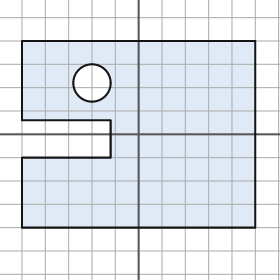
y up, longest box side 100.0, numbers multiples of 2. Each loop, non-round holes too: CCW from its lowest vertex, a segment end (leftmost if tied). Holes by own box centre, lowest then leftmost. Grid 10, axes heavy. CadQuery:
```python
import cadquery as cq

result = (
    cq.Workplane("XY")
    .moveTo(-50.0, -40.0)
    .lineTo(50.0, -40.0)
    .lineTo(50.0, 40.0)
    .lineTo(-50.0, 40.0)
    .lineTo(-50.0, 6.0)
    .lineTo(-12.0, 6.0)
    .lineTo(-12.0, -10.0)
    .lineTo(-50.0, -10.0)
    .close()
    .moveTo(-20.0, 22.0)
    .circle(8.0)
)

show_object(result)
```